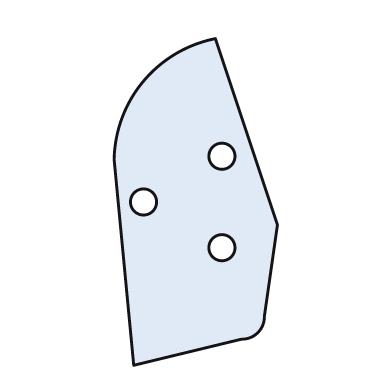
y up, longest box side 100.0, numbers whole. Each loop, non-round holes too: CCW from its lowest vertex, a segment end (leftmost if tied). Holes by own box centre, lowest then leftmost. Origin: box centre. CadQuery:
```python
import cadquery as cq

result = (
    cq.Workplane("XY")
    .moveTo(-19.0, -50.0)
    .lineTo(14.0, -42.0)
    .threePointArc((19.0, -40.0), (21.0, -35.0))
    .lineTo(25.0, -7.0)
    .lineTo(6.0, 50.0)
    .threePointArc((-16.0, 37.0), (-25.0, 13.0))
    .close()
    .moveTo(8.0, -14.0)
    .circle(4.0)
    .moveTo(-16.0, 0.0)
    .circle(4.0)
    .moveTo(8.0, 14.0)
    .circle(4.0)
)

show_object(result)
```